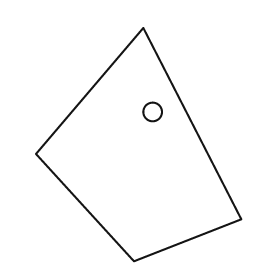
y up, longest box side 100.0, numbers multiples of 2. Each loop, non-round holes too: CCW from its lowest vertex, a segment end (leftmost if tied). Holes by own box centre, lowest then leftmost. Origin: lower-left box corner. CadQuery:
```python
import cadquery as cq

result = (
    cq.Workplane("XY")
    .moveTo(42.0, 0.0)
    .lineTo(88.0, 18.0)
    .lineTo(46.0, 100.0)
    .lineTo(0.0, 46.0)
    .close()
    .moveTo(50.0, 64.0)
    .circle(4.0)
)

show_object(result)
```